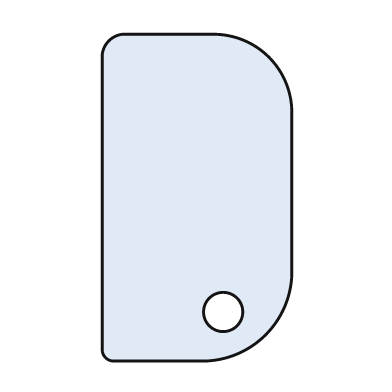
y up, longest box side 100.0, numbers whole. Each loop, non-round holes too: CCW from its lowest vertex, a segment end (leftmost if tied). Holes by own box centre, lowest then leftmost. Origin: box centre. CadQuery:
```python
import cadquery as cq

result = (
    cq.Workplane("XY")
    .moveTo(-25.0, -50.0)
    .lineTo(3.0, -50.0)
    .threePointArc((21.0, -42.0), (29.0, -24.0))
    .lineTo(29.0, 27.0)
    .threePointArc((22.0, 43.0), (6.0, 50.0))
    .lineTo(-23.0, 50.0)
    .threePointArc((-27.0, 48.0), (-29.0, 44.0))
    .lineTo(-29.0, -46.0)
    .threePointArc((-28.0, -49.0), (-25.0, -50.0))
    .close()
    .moveTo(8.0, -35.0)
    .circle(6.0)
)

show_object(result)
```